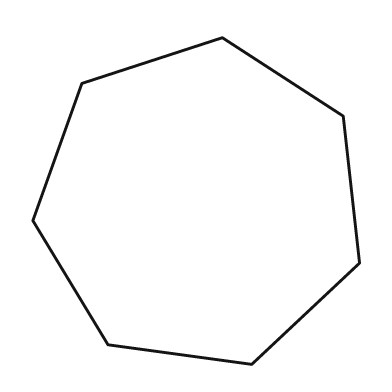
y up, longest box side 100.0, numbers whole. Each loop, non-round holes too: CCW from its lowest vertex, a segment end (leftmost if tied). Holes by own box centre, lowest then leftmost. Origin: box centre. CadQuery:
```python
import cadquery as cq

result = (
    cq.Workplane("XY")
    .moveTo(17.0, -50.0)
    .lineTo(50.0, -19.0)
    .lineTo(45.0, 26.0)
    .lineTo(8.0, 50.0)
    .lineTo(-35.0, 36.0)
    .lineTo(-50.0, -6.0)
    .lineTo(-27.0, -44.0)
    .close()
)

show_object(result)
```